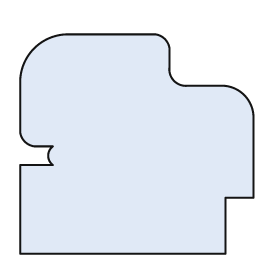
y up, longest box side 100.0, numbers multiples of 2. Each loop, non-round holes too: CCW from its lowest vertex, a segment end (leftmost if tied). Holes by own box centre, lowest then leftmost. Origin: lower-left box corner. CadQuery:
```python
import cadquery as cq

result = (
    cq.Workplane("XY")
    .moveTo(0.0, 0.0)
    .lineTo(88.0, 0.0)
    .lineTo(88.0, 24.0)
    .lineTo(100.0, 24.0)
    .lineTo(100.0, 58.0)
    .threePointArc((96.0, 68.0), (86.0, 72.0))
    .lineTo(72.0, 72.0)
    .threePointArc((66.0, 74.0), (64.0, 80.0))
    .lineTo(64.0, 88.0)
    .threePointArc((62.0, 92.0), (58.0, 94.0))
    .lineTo(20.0, 94.0)
    .threePointArc((6.0, 88.0), (0.0, 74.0))
    .lineTo(0.0, 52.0)
    .threePointArc((2.0, 48.0), (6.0, 46.0))
    .lineTo(14.0, 46.0)
    .threePointArc((12.0, 42.0), (14.0, 38.0))
    .lineTo(0.0, 38.0)
    .close()
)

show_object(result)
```